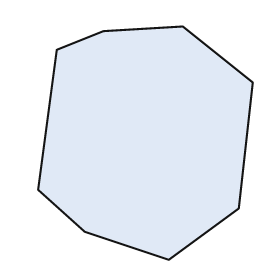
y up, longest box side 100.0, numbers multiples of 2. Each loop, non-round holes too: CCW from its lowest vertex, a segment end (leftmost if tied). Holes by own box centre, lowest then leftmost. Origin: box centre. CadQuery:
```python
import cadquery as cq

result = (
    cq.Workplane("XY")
    .moveTo(10.0, -50.0)
    .lineTo(40.0, -28.0)
    .lineTo(46.0, 26.0)
    .lineTo(16.0, 50.0)
    .lineTo(-18.0, 48.0)
    .lineTo(-38.0, 40.0)
    .lineTo(-46.0, -20.0)
    .lineTo(-26.0, -38.0)
    .close()
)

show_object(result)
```